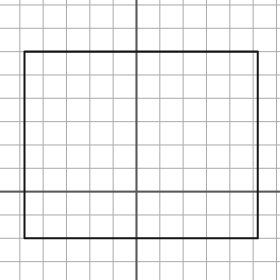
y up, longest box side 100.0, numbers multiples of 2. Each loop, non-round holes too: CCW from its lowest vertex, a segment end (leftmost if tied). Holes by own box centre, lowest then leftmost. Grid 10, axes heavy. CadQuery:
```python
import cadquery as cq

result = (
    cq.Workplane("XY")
    .moveTo(-48.0, -20.0)
    .lineTo(52.0, -20.0)
    .lineTo(52.0, 60.0)
    .lineTo(-48.0, 60.0)
    .close()
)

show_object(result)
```